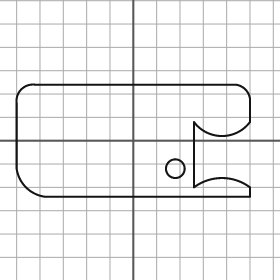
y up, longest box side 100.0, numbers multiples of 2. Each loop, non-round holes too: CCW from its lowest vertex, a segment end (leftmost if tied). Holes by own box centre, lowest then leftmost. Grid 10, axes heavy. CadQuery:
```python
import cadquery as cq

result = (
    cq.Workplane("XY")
    .moveTo(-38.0, -24.0)
    .lineTo(50.0, -24.0)
    .lineTo(50.0, -20.0)
    .threePointArc((38.0, -16.0), (26.0, -20.0))
    .lineTo(26.0, 8.0)
    .threePointArc((38.0, 2.0), (50.0, 8.0))
    .lineTo(50.0, 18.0)
    .threePointArc((48.0, 22.0), (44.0, 24.0))
    .lineTo(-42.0, 24.0)
    .threePointArc((-48.0, 22.0), (-50.0, 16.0))
    .lineTo(-50.0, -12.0)
    .threePointArc((-46.0, -20.0), (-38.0, -24.0))
    .close()
    .moveTo(18.0, -12.0)
    .circle(4.0)
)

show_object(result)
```